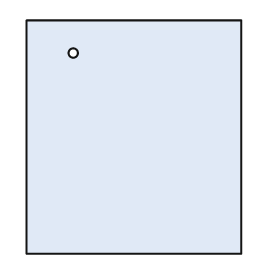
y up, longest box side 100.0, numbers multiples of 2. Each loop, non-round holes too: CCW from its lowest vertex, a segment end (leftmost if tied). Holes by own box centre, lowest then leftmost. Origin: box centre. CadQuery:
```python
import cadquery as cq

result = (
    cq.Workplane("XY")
    .moveTo(-46.0, -50.0)
    .lineTo(46.0, -50.0)
    .lineTo(46.0, 50.0)
    .lineTo(-46.0, 50.0)
    .close()
    .moveTo(-26.0, 36.0)
    .circle(2.0)
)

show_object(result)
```